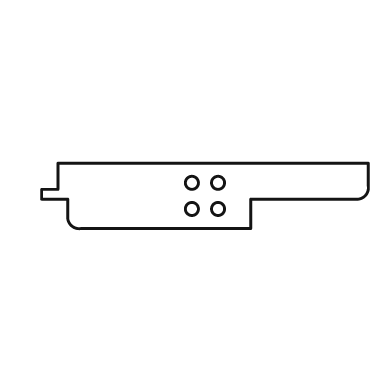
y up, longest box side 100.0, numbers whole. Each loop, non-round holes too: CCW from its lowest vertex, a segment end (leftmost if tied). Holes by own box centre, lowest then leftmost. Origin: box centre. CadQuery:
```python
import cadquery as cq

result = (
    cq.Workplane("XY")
    .moveTo(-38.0, -10.0)
    .lineTo(14.0, -10.0)
    .lineTo(14.0, -1.0)
    .lineTo(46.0, -1.0)
    .threePointArc((49.0, 0.0), (50.0, 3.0))
    .lineTo(50.0, 10.0)
    .lineTo(-45.0, 10.0)
    .lineTo(-45.0, 2.0)
    .lineTo(-50.0, 2.0)
    .lineTo(-50.0, -1.0)
    .lineTo(-42.0, -1.0)
    .lineTo(-42.0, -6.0)
    .threePointArc((-41.0, -9.0), (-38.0, -10.0))
    .close()
    .moveTo(-4.0, -4.0)
    .circle(2.0)
    .moveTo(4.0, -4.0)
    .circle(2.0)
    .moveTo(-4.0, 4.0)
    .circle(2.0)
    .moveTo(4.0, 4.0)
    .circle(2.0)
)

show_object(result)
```